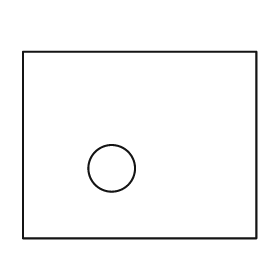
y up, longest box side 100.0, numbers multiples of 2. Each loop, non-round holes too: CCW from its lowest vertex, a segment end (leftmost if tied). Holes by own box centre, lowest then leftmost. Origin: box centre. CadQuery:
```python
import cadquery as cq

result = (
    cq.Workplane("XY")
    .moveTo(-50.0, -40.0)
    .lineTo(50.0, -40.0)
    .lineTo(50.0, 40.0)
    .lineTo(-50.0, 40.0)
    .close()
    .moveTo(-12.0, -10.0)
    .circle(10.0)
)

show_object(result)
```